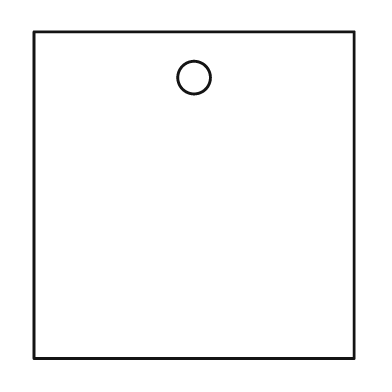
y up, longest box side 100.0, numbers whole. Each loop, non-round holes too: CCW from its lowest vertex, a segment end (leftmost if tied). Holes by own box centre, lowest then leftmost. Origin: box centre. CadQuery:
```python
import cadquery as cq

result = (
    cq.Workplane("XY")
    .moveTo(-49.0, -50.0)
    .lineTo(49.0, -50.0)
    .lineTo(49.0, 50.0)
    .lineTo(-49.0, 50.0)
    .close()
    .moveTo(0.0, 36.0)
    .circle(5.0)
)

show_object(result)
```